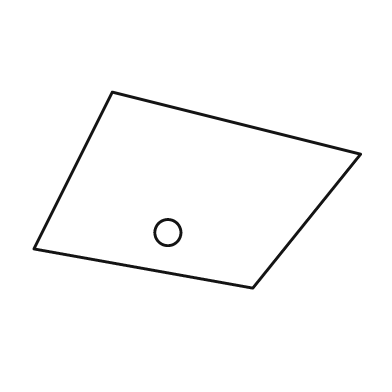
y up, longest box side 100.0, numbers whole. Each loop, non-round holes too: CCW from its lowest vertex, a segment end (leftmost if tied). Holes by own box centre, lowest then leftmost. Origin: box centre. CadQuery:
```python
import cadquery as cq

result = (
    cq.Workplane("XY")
    .moveTo(17.0, -30.0)
    .lineTo(50.0, 11.0)
    .lineTo(-26.0, 30.0)
    .lineTo(-50.0, -18.0)
    .close()
    .moveTo(-9.0, -13.0)
    .circle(4.0)
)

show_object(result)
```